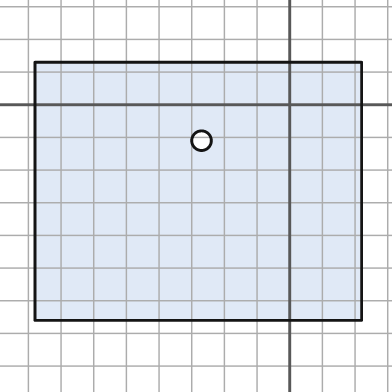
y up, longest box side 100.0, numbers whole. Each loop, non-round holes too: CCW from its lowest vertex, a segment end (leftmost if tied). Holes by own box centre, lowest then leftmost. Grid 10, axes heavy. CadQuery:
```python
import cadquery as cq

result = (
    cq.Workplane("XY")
    .moveTo(-78.0, -66.0)
    .lineTo(22.0, -66.0)
    .lineTo(22.0, 13.0)
    .lineTo(-78.0, 13.0)
    .close()
    .moveTo(-27.0, -11.0)
    .circle(3.0)
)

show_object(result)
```